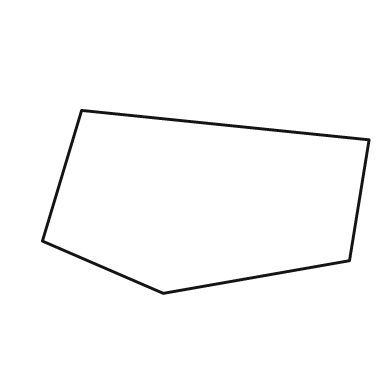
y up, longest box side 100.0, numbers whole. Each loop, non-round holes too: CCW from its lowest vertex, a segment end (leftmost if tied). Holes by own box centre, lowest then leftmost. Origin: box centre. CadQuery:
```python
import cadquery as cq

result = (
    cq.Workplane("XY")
    .moveTo(-13.0, -28.0)
    .lineTo(44.0, -18.0)
    .lineTo(50.0, 19.0)
    .lineTo(-38.0, 28.0)
    .lineTo(-50.0, -12.0)
    .close()
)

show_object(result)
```